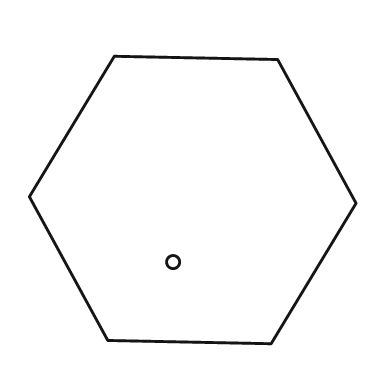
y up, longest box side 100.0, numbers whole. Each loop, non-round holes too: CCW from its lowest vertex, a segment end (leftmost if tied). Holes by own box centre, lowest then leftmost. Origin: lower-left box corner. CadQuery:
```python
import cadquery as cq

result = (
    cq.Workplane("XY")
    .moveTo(74.0, 0.0)
    .lineTo(100.0, 43.0)
    .lineTo(76.0, 87.0)
    .lineTo(26.0, 88.0)
    .lineTo(0.0, 45.0)
    .lineTo(24.0, 1.0)
    .close()
    .moveTo(44.0, 25.0)
    .circle(2.0)
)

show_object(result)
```